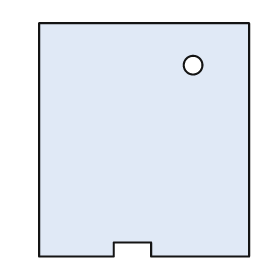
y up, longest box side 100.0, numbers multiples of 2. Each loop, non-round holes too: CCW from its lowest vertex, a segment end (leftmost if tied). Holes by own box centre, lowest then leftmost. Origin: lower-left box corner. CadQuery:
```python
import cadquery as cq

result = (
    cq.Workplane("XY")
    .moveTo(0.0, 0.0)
    .lineTo(32.0, 0.0)
    .lineTo(32.0, 6.0)
    .lineTo(48.0, 6.0)
    .lineTo(48.0, 0.0)
    .lineTo(90.0, 0.0)
    .lineTo(90.0, 100.0)
    .lineTo(0.0, 100.0)
    .close()
    .moveTo(66.0, 82.0)
    .circle(4.0)
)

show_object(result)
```